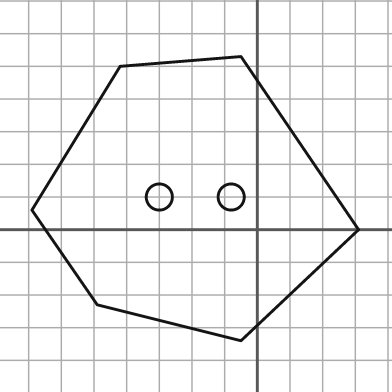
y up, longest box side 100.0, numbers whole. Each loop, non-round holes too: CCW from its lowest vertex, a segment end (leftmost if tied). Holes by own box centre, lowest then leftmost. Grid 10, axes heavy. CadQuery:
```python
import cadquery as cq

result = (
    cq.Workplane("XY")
    .moveTo(-5.0, -34.0)
    .lineTo(31.0, 0.0)
    .lineTo(-5.0, 53.0)
    .lineTo(-42.0, 50.0)
    .lineTo(-69.0, 6.0)
    .lineTo(-49.0, -23.0)
    .close()
    .moveTo(-30.0, 10.0)
    .circle(4.0)
    .moveTo(-8.0, 10.0)
    .circle(4.0)
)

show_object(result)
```